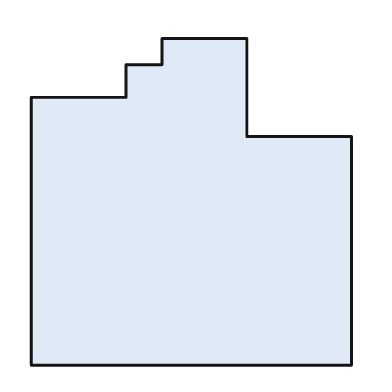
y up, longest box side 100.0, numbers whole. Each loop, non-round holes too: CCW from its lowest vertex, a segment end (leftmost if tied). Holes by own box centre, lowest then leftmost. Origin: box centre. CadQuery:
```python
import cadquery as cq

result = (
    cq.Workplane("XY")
    .moveTo(-49.0, -50.0)
    .lineTo(49.0, -50.0)
    .lineTo(49.0, 20.0)
    .lineTo(17.0, 20.0)
    .lineTo(17.0, 50.0)
    .lineTo(-9.0, 50.0)
    .lineTo(-9.0, 42.0)
    .lineTo(-20.0, 42.0)
    .lineTo(-20.0, 32.0)
    .lineTo(-49.0, 32.0)
    .close()
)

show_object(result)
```